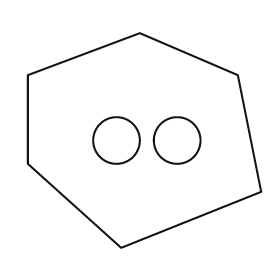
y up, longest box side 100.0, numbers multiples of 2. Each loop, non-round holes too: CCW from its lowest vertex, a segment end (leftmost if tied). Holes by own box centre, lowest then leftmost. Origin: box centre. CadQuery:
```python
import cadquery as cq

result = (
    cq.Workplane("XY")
    .moveTo(-10.0, -46.0)
    .lineTo(50.0, -22.0)
    .lineTo(40.0, 28.0)
    .lineTo(-2.0, 46.0)
    .lineTo(-50.0, 28.0)
    .lineTo(-50.0, -10.0)
    .close()
    .moveTo(-12.0, 0.0)
    .circle(10.0)
    .moveTo(14.0, 0.0)
    .circle(10.0)
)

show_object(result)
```